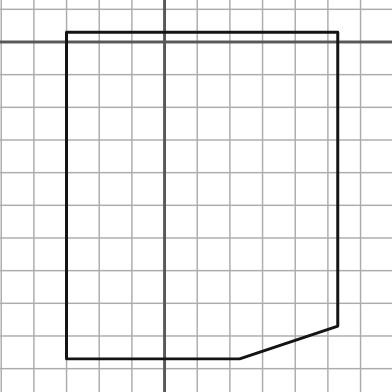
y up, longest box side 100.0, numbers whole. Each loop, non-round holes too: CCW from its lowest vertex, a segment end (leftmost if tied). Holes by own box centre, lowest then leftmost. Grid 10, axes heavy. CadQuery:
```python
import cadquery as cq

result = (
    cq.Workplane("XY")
    .moveTo(-30.0, -97.0)
    .lineTo(23.0, -97.0)
    .lineTo(53.0, -87.0)
    .lineTo(53.0, 3.0)
    .lineTo(-30.0, 3.0)
    .close()
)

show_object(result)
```